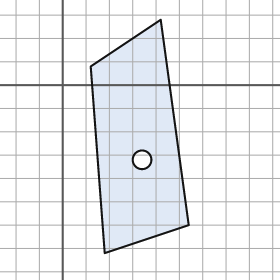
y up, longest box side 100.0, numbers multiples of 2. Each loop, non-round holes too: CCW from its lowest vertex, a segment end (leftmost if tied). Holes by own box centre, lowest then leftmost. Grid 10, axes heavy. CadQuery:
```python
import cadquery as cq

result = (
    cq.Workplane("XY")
    .moveTo(18.0, -72.0)
    .lineTo(54.0, -60.0)
    .lineTo(42.0, 28.0)
    .lineTo(12.0, 8.0)
    .close()
    .moveTo(34.0, -32.0)
    .circle(4.0)
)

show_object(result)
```